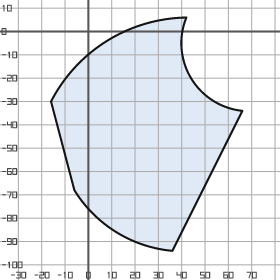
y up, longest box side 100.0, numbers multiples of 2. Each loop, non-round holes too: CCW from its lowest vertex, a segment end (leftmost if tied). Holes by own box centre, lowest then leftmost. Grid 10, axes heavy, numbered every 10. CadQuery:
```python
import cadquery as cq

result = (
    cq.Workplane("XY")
    .moveTo(36.0, -94.0)
    .lineTo(66.0, -34.0)
    .threePointArc((44.0, -20.0), (42.0, 6.0))
    .threePointArc((8.0, -4.0), (-16.0, -30.0))
    .lineTo(-6.0, -68.0)
    .threePointArc((12.0, -86.0), (36.0, -94.0))
    .close()
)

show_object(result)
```